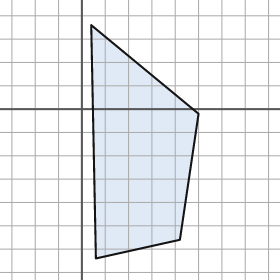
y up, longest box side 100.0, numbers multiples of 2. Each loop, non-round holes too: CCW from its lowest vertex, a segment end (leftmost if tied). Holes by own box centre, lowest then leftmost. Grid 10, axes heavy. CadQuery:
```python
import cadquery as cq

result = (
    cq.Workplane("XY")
    .moveTo(6.0, -64.0)
    .lineTo(42.0, -56.0)
    .lineTo(50.0, -2.0)
    .lineTo(4.0, 36.0)
    .close()
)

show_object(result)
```